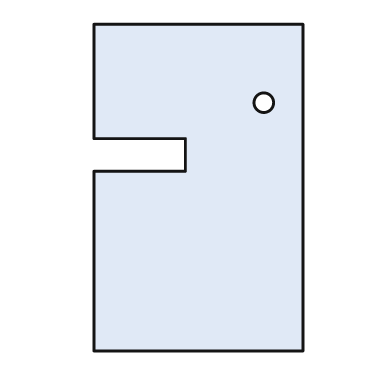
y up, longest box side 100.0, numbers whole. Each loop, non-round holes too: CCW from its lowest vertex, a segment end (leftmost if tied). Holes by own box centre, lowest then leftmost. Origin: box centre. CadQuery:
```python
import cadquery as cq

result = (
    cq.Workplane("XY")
    .moveTo(-32.0, -50.0)
    .lineTo(32.0, -50.0)
    .lineTo(32.0, 50.0)
    .lineTo(-32.0, 50.0)
    .lineTo(-32.0, 15.0)
    .lineTo(-4.0, 15.0)
    .lineTo(-4.0, 5.0)
    .lineTo(-32.0, 5.0)
    .close()
    .moveTo(20.0, 26.0)
    .circle(3.0)
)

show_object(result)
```